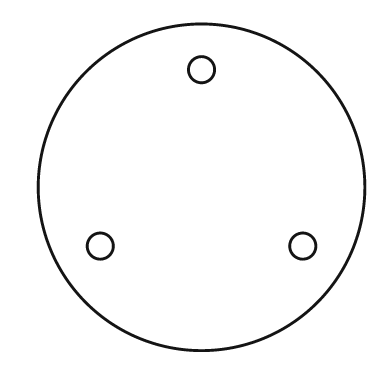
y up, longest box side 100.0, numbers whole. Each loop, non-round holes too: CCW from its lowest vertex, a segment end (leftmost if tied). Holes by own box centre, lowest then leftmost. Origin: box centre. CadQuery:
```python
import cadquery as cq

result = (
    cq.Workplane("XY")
    .moveTo(0.0, 0.0)
    .circle(50.0)
    .moveTo(-31.0, -18.0)
    .circle(4.0)
    .moveTo(31.0, -18.0)
    .circle(4.0)
    .moveTo(0.0, 36.0)
    .circle(4.0)
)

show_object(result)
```